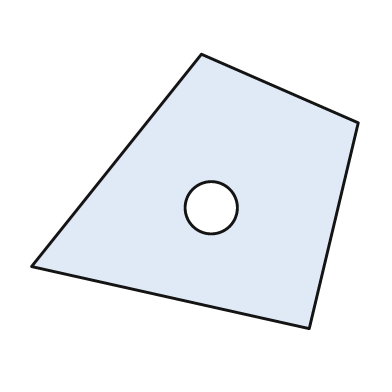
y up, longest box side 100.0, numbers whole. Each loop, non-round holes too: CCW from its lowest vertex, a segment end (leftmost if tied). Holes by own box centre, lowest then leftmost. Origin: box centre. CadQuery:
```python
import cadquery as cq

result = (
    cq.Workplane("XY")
    .moveTo(35.0, -42.0)
    .lineTo(50.0, 21.0)
    .lineTo(2.0, 42.0)
    .lineTo(-50.0, -23.0)
    .close()
    .moveTo(5.0, -5.0)
    .circle(8.0)
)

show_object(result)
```